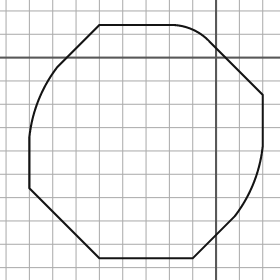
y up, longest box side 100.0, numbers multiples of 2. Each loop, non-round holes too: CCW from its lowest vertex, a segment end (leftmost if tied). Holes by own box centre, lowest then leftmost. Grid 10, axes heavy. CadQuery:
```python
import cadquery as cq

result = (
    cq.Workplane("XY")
    .moveTo(-50.0, -86.0)
    .lineTo(-10.0, -86.0)
    .lineTo(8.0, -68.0)
    .threePointArc((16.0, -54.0), (20.0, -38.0))
    .lineTo(20.0, -16.0)
    .lineTo(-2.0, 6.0)
    .threePointArc((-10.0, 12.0), (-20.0, 14.0))
    .lineTo(-50.0, 14.0)
    .lineTo(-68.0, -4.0)
    .threePointArc((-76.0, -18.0), (-80.0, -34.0))
    .lineTo(-80.0, -56.0)
    .close()
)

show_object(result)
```